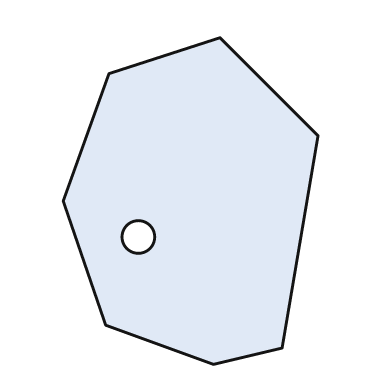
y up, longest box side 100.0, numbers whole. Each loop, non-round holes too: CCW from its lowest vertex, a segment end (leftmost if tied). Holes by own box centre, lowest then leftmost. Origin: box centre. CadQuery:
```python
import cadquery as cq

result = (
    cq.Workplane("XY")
    .moveTo(7.0, -50.0)
    .lineTo(28.0, -45.0)
    .lineTo(39.0, 20.0)
    .lineTo(9.0, 50.0)
    .lineTo(-25.0, 39.0)
    .lineTo(-39.0, 0.0)
    .lineTo(-26.0, -38.0)
    .close()
    .moveTo(-16.0, -11.0)
    .circle(5.0)
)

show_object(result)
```